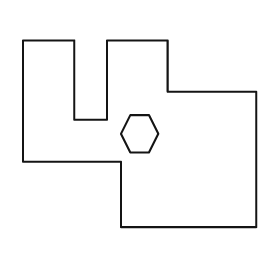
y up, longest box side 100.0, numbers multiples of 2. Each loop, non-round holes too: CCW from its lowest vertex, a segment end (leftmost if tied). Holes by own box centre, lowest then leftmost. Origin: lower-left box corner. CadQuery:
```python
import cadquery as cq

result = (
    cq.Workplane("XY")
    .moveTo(42.0, 0.0)
    .lineTo(100.0, 0.0)
    .lineTo(100.0, 58.0)
    .lineTo(62.0, 58.0)
    .lineTo(62.0, 80.0)
    .lineTo(36.0, 80.0)
    .lineTo(36.0, 46.0)
    .lineTo(22.0, 46.0)
    .lineTo(22.0, 80.0)
    .lineTo(0.0, 80.0)
    .lineTo(0.0, 28.0)
    .lineTo(42.0, 28.0)
    .close()
    .moveTo(46.0, 32.0)
    .lineTo(54.0, 32.0)
    .lineTo(58.0, 40.0)
    .lineTo(54.0, 48.0)
    .lineTo(46.0, 48.0)
    .lineTo(42.0, 40.0)
    .close()
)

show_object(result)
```